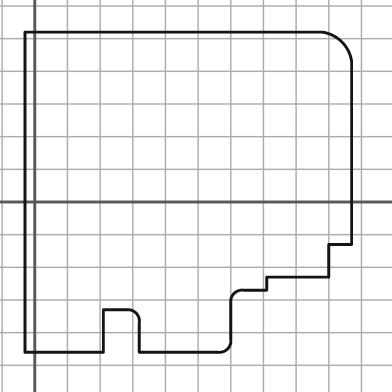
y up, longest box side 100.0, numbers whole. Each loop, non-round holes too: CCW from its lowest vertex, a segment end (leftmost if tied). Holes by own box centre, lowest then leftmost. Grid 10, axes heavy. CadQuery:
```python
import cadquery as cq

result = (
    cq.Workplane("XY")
    .moveTo(-3.0, -46.0)
    .lineTo(21.0, -46.0)
    .lineTo(21.0, -33.0)
    .lineTo(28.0, -33.0)
    .threePointArc((31.0, -34.0), (32.0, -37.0))
    .lineTo(32.0, -46.0)
    .lineTo(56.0, -46.0)
    .threePointArc((59.0, -45.0), (60.0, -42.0))
    .lineTo(60.0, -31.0)
    .threePointArc((61.0, -28.0), (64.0, -27.0))
    .lineTo(71.0, -27.0)
    .lineTo(71.0, -23.0)
    .lineTo(90.0, -23.0)
    .lineTo(90.0, -13.0)
    .lineTo(97.0, -13.0)
    .lineTo(97.0, 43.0)
    .threePointArc((94.0, 49.0), (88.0, 52.0))
    .lineTo(-3.0, 52.0)
    .close()
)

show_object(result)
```